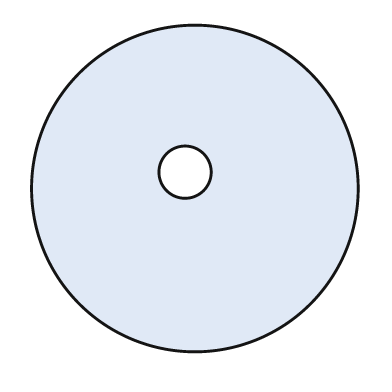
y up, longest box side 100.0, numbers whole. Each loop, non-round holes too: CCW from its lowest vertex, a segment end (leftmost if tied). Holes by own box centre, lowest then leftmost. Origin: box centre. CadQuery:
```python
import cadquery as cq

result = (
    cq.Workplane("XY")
    .moveTo(0.0, 0.0)
    .circle(50.0)
    .moveTo(-3.0, 5.0)
    .circle(8.0)
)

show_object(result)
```